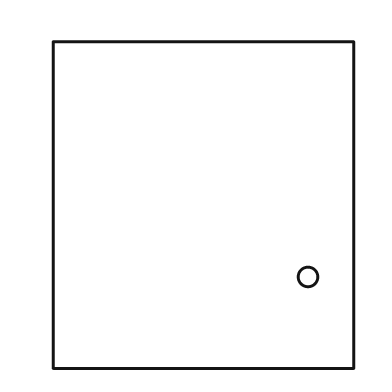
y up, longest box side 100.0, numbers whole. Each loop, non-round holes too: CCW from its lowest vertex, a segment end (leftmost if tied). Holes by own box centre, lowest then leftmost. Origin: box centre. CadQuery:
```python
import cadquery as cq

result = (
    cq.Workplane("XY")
    .moveTo(-46.0, -50.0)
    .lineTo(46.0, -50.0)
    .lineTo(46.0, 50.0)
    .lineTo(-46.0, 50.0)
    .close()
    .moveTo(32.0, -22.0)
    .circle(3.0)
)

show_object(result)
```